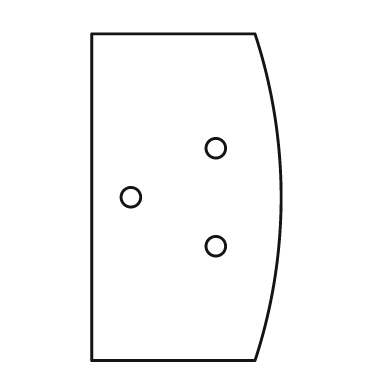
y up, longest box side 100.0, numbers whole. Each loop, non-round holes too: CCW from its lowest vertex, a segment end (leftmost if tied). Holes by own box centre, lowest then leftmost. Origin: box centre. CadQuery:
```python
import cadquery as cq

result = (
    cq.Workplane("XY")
    .moveTo(-29.0, -50.0)
    .lineTo(21.0, -50.0)
    .threePointArc((29.0, 0.0), (21.0, 50.0))
    .lineTo(-29.0, 50.0)
    .close()
    .moveTo(9.0, -15.0)
    .circle(3.0)
    .moveTo(-17.0, 0.0)
    .circle(3.0)
    .moveTo(9.0, 15.0)
    .circle(3.0)
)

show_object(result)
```